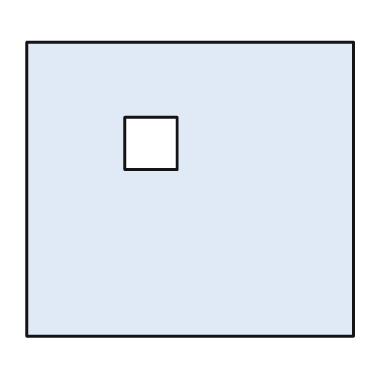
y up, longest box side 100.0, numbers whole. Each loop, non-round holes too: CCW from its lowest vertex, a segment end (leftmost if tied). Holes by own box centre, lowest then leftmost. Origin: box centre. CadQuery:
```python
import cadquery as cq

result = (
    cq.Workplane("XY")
    .moveTo(-50.0, -45.0)
    .lineTo(50.0, -45.0)
    .lineTo(50.0, 45.0)
    .lineTo(-50.0, 45.0)
    .close()
    .moveTo(-20.0, 6.0)
    .lineTo(-4.0, 6.0)
    .lineTo(-4.0, 22.0)
    .lineTo(-20.0, 22.0)
    .close()
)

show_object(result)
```